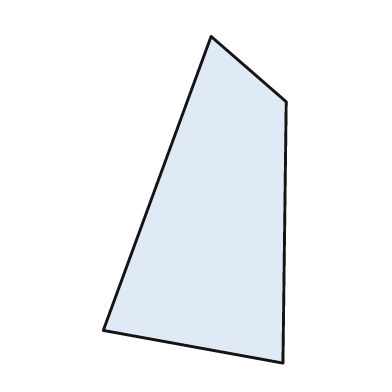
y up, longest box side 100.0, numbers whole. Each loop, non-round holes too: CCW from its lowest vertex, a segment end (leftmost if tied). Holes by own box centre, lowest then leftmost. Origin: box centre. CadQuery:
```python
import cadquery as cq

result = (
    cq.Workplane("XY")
    .moveTo(27.0, -50.0)
    .lineTo(28.0, 30.0)
    .lineTo(5.0, 50.0)
    .lineTo(-28.0, -40.0)
    .close()
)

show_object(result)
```